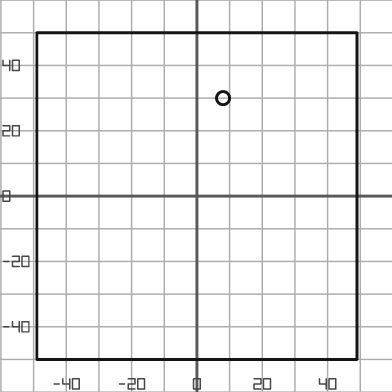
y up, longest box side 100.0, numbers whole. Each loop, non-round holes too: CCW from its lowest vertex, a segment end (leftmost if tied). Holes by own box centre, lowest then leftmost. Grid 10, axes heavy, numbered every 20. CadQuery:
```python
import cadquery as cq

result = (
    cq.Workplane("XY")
    .moveTo(-49.0, -50.0)
    .lineTo(49.0, -50.0)
    .lineTo(49.0, 50.0)
    .lineTo(-49.0, 50.0)
    .close()
    .moveTo(8.0, 30.0)
    .circle(2.0)
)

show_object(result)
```